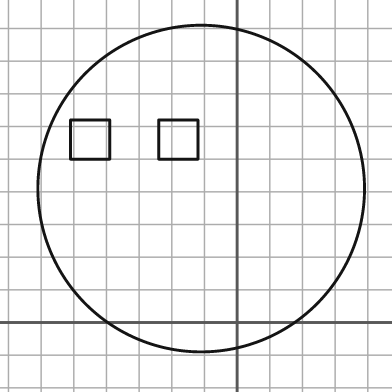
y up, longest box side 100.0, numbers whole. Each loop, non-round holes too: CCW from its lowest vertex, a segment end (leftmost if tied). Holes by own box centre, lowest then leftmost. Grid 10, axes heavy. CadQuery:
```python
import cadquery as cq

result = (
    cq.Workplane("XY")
    .moveTo(-11.0, 41.0)
    .circle(50.0)
    .moveTo(-51.0, 50.0)
    .lineTo(-39.0, 50.0)
    .lineTo(-39.0, 62.0)
    .lineTo(-51.0, 62.0)
    .close()
    .moveTo(-24.0, 50.0)
    .lineTo(-12.0, 50.0)
    .lineTo(-12.0, 62.0)
    .lineTo(-24.0, 62.0)
    .close()
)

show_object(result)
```